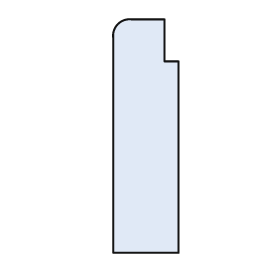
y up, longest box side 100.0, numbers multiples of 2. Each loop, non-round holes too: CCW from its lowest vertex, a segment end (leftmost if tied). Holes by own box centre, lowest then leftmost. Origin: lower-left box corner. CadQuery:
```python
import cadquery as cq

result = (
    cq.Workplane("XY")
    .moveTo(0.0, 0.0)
    .lineTo(28.0, 0.0)
    .lineTo(28.0, 82.0)
    .lineTo(22.0, 82.0)
    .lineTo(22.0, 100.0)
    .lineTo(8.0, 100.0)
    .threePointArc((2.0, 98.0), (0.0, 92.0))
    .close()
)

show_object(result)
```